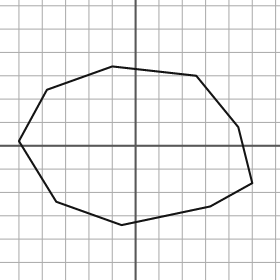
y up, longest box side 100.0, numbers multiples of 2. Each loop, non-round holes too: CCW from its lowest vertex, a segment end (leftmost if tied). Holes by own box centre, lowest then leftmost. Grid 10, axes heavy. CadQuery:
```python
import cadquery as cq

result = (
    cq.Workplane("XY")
    .moveTo(-6.0, -34.0)
    .lineTo(32.0, -26.0)
    .lineTo(50.0, -16.0)
    .lineTo(44.0, 8.0)
    .lineTo(26.0, 30.0)
    .lineTo(-10.0, 34.0)
    .lineTo(-38.0, 24.0)
    .lineTo(-50.0, 2.0)
    .lineTo(-34.0, -24.0)
    .close()
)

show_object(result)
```